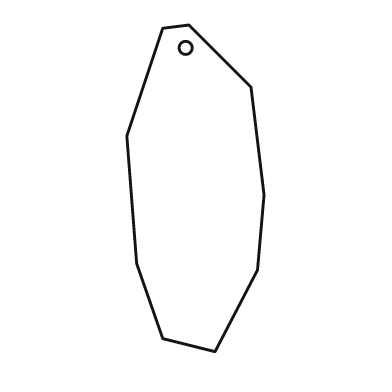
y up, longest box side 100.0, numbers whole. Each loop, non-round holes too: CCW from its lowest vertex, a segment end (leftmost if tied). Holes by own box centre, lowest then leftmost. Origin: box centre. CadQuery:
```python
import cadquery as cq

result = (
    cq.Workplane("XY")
    .moveTo(6.0, -50.0)
    .lineTo(19.0, -25.0)
    .lineTo(21.0, -2.0)
    .lineTo(17.0, 31.0)
    .lineTo(-2.0, 50.0)
    .lineTo(-10.0, 49.0)
    .lineTo(-21.0, 16.0)
    .lineTo(-18.0, -23.0)
    .lineTo(-10.0, -46.0)
    .close()
    .moveTo(-3.0, 43.0)
    .circle(2.0)
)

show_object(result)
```